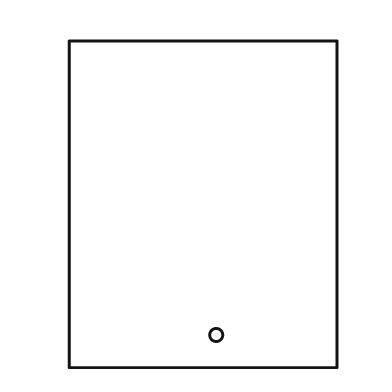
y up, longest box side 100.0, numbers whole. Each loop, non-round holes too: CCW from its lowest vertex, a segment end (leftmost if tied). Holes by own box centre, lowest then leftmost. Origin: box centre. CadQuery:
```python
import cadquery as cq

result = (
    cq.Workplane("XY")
    .moveTo(-41.0, -50.0)
    .lineTo(41.0, -50.0)
    .lineTo(41.0, 50.0)
    .lineTo(-41.0, 50.0)
    .close()
    .moveTo(4.0, -40.0)
    .circle(2.0)
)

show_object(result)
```